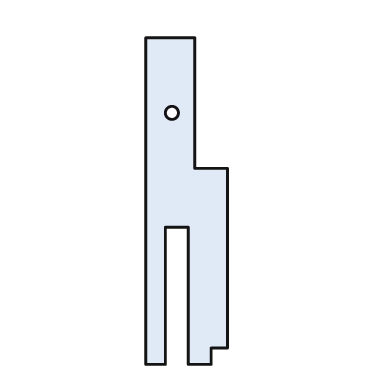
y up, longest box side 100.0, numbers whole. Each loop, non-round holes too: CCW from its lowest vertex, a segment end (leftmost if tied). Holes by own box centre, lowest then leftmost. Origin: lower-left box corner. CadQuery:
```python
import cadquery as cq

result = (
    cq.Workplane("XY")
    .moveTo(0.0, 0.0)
    .lineTo(6.0, 0.0)
    .lineTo(6.0, 42.0)
    .lineTo(13.0, 42.0)
    .lineTo(13.0, 0.0)
    .lineTo(20.0, 0.0)
    .lineTo(20.0, 5.0)
    .lineTo(25.0, 5.0)
    .lineTo(25.0, 60.0)
    .lineTo(15.0, 60.0)
    .lineTo(15.0, 100.0)
    .lineTo(0.0, 100.0)
    .close()
    .moveTo(8.0, 77.0)
    .circle(2.0)
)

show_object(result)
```